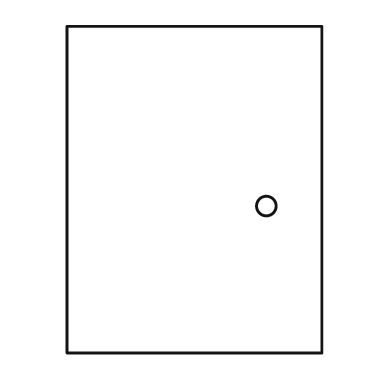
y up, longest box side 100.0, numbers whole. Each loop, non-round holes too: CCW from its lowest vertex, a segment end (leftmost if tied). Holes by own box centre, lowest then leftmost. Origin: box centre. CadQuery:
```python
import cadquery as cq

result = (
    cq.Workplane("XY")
    .moveTo(-39.0, -50.0)
    .lineTo(39.0, -50.0)
    .lineTo(39.0, 50.0)
    .lineTo(-39.0, 50.0)
    .close()
    .moveTo(22.0, -5.0)
    .circle(3.0)
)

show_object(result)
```